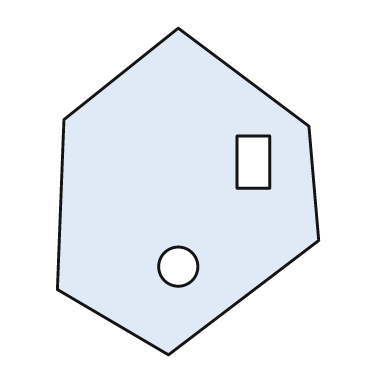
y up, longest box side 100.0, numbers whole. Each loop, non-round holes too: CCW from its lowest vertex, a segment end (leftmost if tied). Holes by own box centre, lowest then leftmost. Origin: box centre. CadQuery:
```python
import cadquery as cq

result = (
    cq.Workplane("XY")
    .moveTo(-6.0, -50.0)
    .lineTo(40.0, -15.0)
    .lineTo(37.0, 20.0)
    .lineTo(-3.0, 50.0)
    .lineTo(-38.0, 22.0)
    .lineTo(-40.0, -30.0)
    .close()
    .moveTo(-3.0, -23.0)
    .circle(6.0)
    .moveTo(15.0, 1.0)
    .lineTo(25.0, 1.0)
    .lineTo(25.0, 17.0)
    .lineTo(15.0, 17.0)
    .close()
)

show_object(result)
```